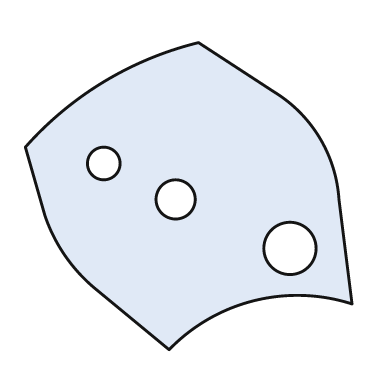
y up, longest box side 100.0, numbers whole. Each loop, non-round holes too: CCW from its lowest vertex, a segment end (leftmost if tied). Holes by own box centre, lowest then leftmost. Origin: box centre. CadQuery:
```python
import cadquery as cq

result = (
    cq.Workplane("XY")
    .moveTo(-6.0, -47.0)
    .threePointArc((20.0, -32.0), (50.0, -33.0))
    .lineTo(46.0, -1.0)
    .threePointArc((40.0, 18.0), (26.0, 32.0))
    .lineTo(3.0, 47.0)
    .threePointArc((-26.0, 35.0), (-50.0, 15.0))
    .lineTo(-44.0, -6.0)
    .threePointArc((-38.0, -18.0), (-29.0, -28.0))
    .close()
    .moveTo(31.0, -16.0)
    .circle(8.0)
    .moveTo(-4.0, -1.0)
    .circle(6.0)
    .moveTo(-26.0, 10.0)
    .circle(5.0)
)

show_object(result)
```